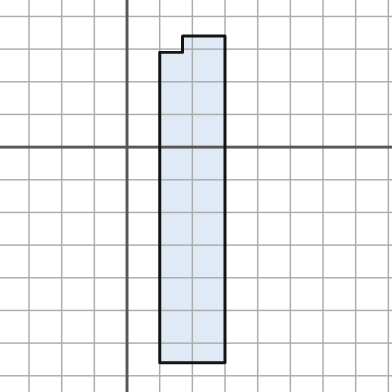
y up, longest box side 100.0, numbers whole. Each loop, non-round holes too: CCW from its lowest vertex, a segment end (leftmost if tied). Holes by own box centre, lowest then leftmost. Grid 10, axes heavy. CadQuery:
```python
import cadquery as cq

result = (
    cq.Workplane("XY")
    .moveTo(10.0, -66.0)
    .lineTo(30.0, -66.0)
    .lineTo(30.0, 34.0)
    .lineTo(17.0, 34.0)
    .lineTo(17.0, 29.0)
    .lineTo(10.0, 29.0)
    .close()
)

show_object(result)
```